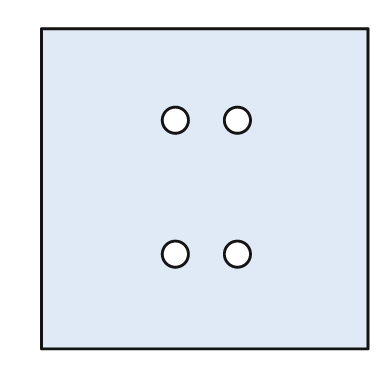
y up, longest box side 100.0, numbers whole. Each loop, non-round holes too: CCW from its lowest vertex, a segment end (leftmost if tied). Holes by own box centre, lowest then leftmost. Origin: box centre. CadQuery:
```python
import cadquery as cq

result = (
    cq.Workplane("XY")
    .moveTo(-50.0, -49.0)
    .lineTo(50.0, -49.0)
    .lineTo(50.0, 49.0)
    .lineTo(-50.0, 49.0)
    .close()
    .moveTo(-9.0, -20.0)
    .circle(4.0)
    .moveTo(10.0, -20.0)
    .circle(4.0)
    .moveTo(-9.0, 21.0)
    .circle(4.0)
    .moveTo(10.0, 21.0)
    .circle(4.0)
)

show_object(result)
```